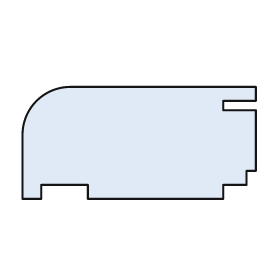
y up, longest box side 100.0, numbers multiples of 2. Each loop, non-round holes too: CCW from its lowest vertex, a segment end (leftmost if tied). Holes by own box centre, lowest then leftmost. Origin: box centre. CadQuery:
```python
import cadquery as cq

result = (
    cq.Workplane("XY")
    .moveTo(-50.0, -24.0)
    .lineTo(-42.0, -24.0)
    .lineTo(-42.0, -18.0)
    .lineTo(-22.0, -18.0)
    .lineTo(-22.0, -24.0)
    .lineTo(36.0, -24.0)
    .lineTo(36.0, -18.0)
    .lineTo(46.0, -18.0)
    .lineTo(46.0, -12.0)
    .lineTo(50.0, -12.0)
    .lineTo(50.0, 14.0)
    .lineTo(36.0, 14.0)
    .lineTo(36.0, 18.0)
    .lineTo(50.0, 18.0)
    .lineTo(50.0, 24.0)
    .lineTo(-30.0, 24.0)
    .threePointArc((-44.0, 18.0), (-50.0, 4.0))
    .close()
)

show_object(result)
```